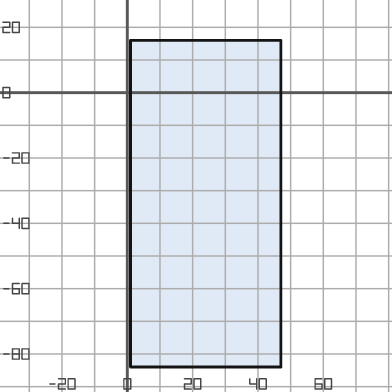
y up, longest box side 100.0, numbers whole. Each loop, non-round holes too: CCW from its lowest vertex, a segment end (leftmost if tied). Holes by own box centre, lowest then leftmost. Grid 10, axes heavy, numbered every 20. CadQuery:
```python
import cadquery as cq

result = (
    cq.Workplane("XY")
    .moveTo(1.0, -84.0)
    .lineTo(47.0, -84.0)
    .lineTo(47.0, 16.0)
    .lineTo(1.0, 16.0)
    .close()
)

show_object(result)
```